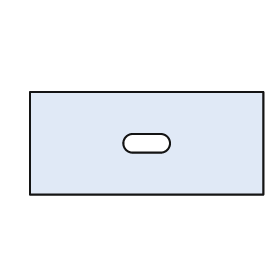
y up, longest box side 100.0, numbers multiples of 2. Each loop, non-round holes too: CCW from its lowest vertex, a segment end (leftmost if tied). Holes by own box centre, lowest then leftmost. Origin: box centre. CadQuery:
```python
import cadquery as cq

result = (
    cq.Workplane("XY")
    .moveTo(-50.0, -22.0)
    .lineTo(50.0, -22.0)
    .lineTo(50.0, 22.0)
    .lineTo(-50.0, 22.0)
    .close()
    .moveTo(-6.0, -4.0)
    .lineTo(6.0, -4.0)
    .threePointArc((10.0, 0.0), (6.0, 4.0))
    .lineTo(-6.0, 4.0)
    .threePointArc((-10.0, 0.0), (-6.0, -4.0))
    .close()
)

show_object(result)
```